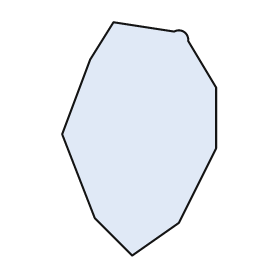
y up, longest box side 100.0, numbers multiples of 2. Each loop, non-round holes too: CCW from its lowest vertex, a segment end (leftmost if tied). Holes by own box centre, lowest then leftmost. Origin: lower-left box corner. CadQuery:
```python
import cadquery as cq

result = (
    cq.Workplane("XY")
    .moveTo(30.0, 0.0)
    .lineTo(50.0, 14.0)
    .lineTo(66.0, 46.0)
    .lineTo(66.0, 72.0)
    .lineTo(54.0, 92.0)
    .threePointArc((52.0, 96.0), (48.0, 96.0))
    .lineTo(22.0, 100.0)
    .lineTo(12.0, 84.0)
    .lineTo(0.0, 52.0)
    .lineTo(14.0, 16.0)
    .close()
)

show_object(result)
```